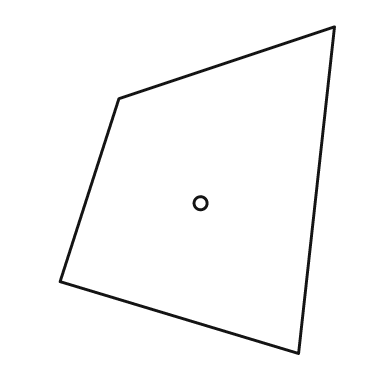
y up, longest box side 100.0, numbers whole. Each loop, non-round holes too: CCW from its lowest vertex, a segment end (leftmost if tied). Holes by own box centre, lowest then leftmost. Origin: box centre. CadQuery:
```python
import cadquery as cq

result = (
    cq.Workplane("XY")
    .moveTo(31.0, -50.0)
    .lineTo(42.0, 50.0)
    .lineTo(-24.0, 28.0)
    .lineTo(-42.0, -28.0)
    .close()
    .moveTo(1.0, -4.0)
    .circle(2.0)
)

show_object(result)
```